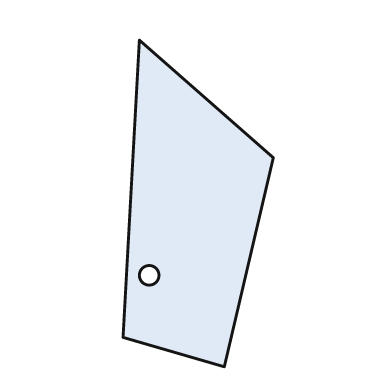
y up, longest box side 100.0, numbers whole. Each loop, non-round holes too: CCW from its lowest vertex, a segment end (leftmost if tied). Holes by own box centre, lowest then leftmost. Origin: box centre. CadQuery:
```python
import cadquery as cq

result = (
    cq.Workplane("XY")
    .moveTo(8.0, -50.0)
    .lineTo(23.0, 14.0)
    .lineTo(-18.0, 50.0)
    .lineTo(-23.0, -41.0)
    .close()
    .moveTo(-15.0, -22.0)
    .circle(3.0)
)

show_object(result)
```